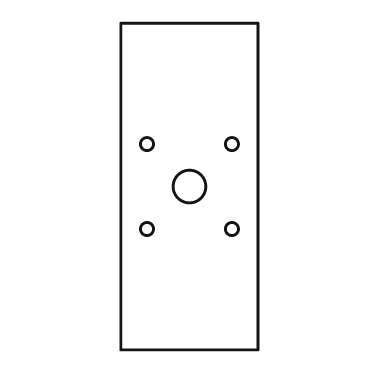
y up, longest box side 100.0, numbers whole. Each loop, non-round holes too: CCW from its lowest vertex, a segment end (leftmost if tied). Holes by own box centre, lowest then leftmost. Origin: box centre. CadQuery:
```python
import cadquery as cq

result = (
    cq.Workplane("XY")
    .moveTo(-21.0, -50.0)
    .lineTo(21.0, -50.0)
    .lineTo(21.0, 50.0)
    .lineTo(-21.0, 50.0)
    .close()
    .moveTo(-13.0, -13.0)
    .circle(2.0)
    .moveTo(13.0, -13.0)
    .circle(2.0)
    .moveTo(0.0, 0.0)
    .circle(5.0)
    .moveTo(-13.0, 13.0)
    .circle(2.0)
    .moveTo(13.0, 13.0)
    .circle(2.0)
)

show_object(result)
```